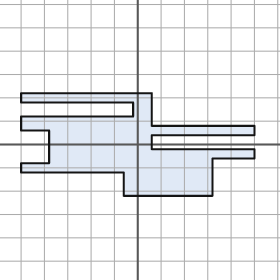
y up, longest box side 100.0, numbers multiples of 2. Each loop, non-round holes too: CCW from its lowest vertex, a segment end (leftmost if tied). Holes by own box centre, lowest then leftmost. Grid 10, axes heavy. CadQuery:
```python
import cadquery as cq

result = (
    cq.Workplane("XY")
    .moveTo(-6.0, -22.0)
    .lineTo(32.0, -22.0)
    .lineTo(32.0, -6.0)
    .lineTo(50.0, -6.0)
    .lineTo(50.0, -2.0)
    .lineTo(6.0, -2.0)
    .lineTo(6.0, 4.0)
    .lineTo(50.0, 4.0)
    .lineTo(50.0, 8.0)
    .lineTo(6.0, 8.0)
    .lineTo(6.0, 22.0)
    .lineTo(-50.0, 22.0)
    .lineTo(-50.0, 18.0)
    .lineTo(-2.0, 18.0)
    .lineTo(-2.0, 12.0)
    .lineTo(-50.0, 12.0)
    .lineTo(-50.0, 6.0)
    .lineTo(-38.0, 6.0)
    .lineTo(-38.0, -8.0)
    .lineTo(-50.0, -8.0)
    .lineTo(-50.0, -12.0)
    .lineTo(-6.0, -12.0)
    .close()
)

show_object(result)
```